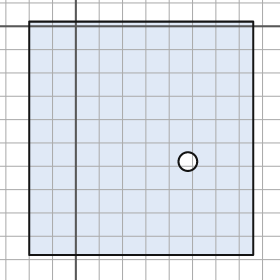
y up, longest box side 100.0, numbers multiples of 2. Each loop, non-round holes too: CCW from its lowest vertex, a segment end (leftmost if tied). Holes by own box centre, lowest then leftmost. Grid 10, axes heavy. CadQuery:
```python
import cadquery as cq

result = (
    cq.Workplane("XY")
    .moveTo(-20.0, -98.0)
    .lineTo(76.0, -98.0)
    .lineTo(76.0, 2.0)
    .lineTo(-20.0, 2.0)
    .close()
    .moveTo(48.0, -58.0)
    .circle(4.0)
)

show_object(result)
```